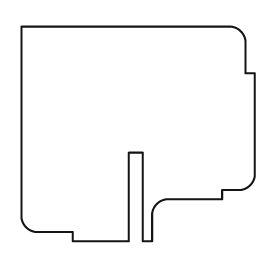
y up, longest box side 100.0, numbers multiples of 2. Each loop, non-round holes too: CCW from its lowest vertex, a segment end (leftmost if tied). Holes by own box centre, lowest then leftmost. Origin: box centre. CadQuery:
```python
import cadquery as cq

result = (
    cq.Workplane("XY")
    .moveTo(-28.0, -46.0)
    .lineTo(-4.0, -46.0)
    .lineTo(-4.0, -8.0)
    .lineTo(2.0, -8.0)
    .lineTo(2.0, -46.0)
    .lineTo(6.0, -46.0)
    .lineTo(6.0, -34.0)
    .threePointArc((8.0, -30.0), (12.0, -28.0))
    .lineTo(36.0, -28.0)
    .lineTo(36.0, -24.0)
    .lineTo(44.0, -24.0)
    .threePointArc((48.0, -22.0), (50.0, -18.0))
    .lineTo(50.0, 26.0)
    .lineTo(46.0, 26.0)
    .lineTo(46.0, 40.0)
    .threePointArc((44.0, 44.0), (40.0, 46.0))
    .lineTo(-50.0, 46.0)
    .lineTo(-50.0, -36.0)
    .threePointArc((-48.0, -40.0), (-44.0, -42.0))
    .lineTo(-28.0, -42.0)
    .close()
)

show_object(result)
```